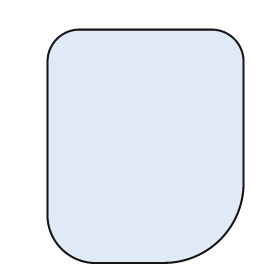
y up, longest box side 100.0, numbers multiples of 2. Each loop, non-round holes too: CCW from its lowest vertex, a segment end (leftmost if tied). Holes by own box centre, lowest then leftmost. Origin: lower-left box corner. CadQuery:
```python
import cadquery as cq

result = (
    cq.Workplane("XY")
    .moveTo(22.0, 0.0)
    .lineTo(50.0, 0.0)
    .threePointArc((74.0, 10.0), (84.0, 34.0))
    .lineTo(84.0, 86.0)
    .threePointArc((80.0, 96.0), (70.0, 100.0))
    .lineTo(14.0, 100.0)
    .threePointArc((4.0, 96.0), (0.0, 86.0))
    .lineTo(0.0, 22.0)
    .threePointArc((6.0, 6.0), (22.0, 0.0))
    .close()
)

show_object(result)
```